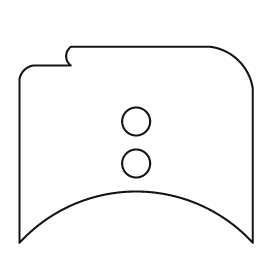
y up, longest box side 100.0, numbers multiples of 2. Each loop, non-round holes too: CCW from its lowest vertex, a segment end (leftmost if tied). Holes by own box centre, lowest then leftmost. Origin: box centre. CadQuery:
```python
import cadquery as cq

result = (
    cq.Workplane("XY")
    .moveTo(-50.0, -42.0)
    .threePointArc((0.0, -20.0), (50.0, -42.0))
    .lineTo(50.0, 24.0)
    .threePointArc((44.0, 36.0), (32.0, 42.0))
    .lineTo(-28.0, 42.0)
    .threePointArc((-30.0, 38.0), (-28.0, 34.0))
    .lineTo(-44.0, 34.0)
    .threePointArc((-48.0, 32.0), (-50.0, 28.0))
    .close()
    .moveTo(0.0, -8.0)
    .circle(6.0)
    .moveTo(0.0, 10.0)
    .circle(6.0)
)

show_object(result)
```